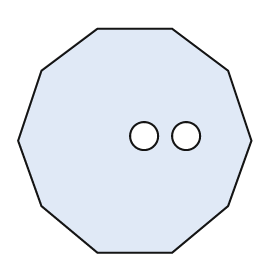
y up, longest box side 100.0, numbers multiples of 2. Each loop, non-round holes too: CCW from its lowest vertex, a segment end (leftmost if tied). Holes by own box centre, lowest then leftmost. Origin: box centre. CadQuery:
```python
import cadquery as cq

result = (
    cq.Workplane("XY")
    .moveTo(-16.0, -48.0)
    .lineTo(16.0, -48.0)
    .lineTo(40.0, -28.0)
    .lineTo(50.0, 0.0)
    .lineTo(40.0, 30.0)
    .lineTo(16.0, 48.0)
    .lineTo(-16.0, 48.0)
    .lineTo(-40.0, 30.0)
    .lineTo(-50.0, 0.0)
    .lineTo(-40.0, -28.0)
    .close()
    .moveTo(4.0, 2.0)
    .circle(6.0)
    .moveTo(22.0, 2.0)
    .circle(6.0)
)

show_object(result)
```